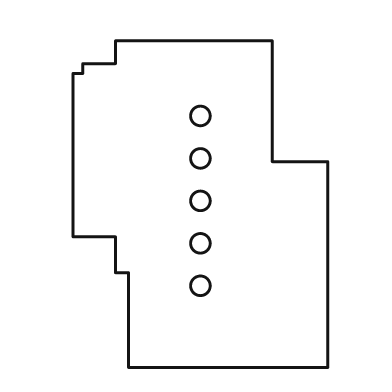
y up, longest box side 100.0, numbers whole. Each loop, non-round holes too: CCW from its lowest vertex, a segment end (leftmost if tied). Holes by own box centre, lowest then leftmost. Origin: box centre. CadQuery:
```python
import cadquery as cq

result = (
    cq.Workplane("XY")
    .moveTo(-22.0, -50.0)
    .lineTo(39.0, -50.0)
    .lineTo(39.0, 13.0)
    .lineTo(22.0, 13.0)
    .lineTo(22.0, 50.0)
    .lineTo(-26.0, 50.0)
    .lineTo(-26.0, 43.0)
    .lineTo(-36.0, 43.0)
    .lineTo(-36.0, 40.0)
    .lineTo(-39.0, 40.0)
    .lineTo(-39.0, -10.0)
    .lineTo(-26.0, -10.0)
    .lineTo(-26.0, -21.0)
    .lineTo(-22.0, -21.0)
    .close()
    .moveTo(0.0, -25.0)
    .circle(3.0)
    .moveTo(0.0, -12.0)
    .circle(3.0)
    .moveTo(0.0, 1.0)
    .circle(3.0)
    .moveTo(0.0, 14.0)
    .circle(3.0)
    .moveTo(0.0, 27.0)
    .circle(3.0)
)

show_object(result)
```